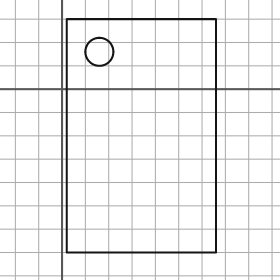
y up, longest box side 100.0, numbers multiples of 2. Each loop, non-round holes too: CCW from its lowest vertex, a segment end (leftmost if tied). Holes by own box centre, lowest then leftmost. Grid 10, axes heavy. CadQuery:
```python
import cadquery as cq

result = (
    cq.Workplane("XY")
    .moveTo(2.0, -70.0)
    .lineTo(66.0, -70.0)
    .lineTo(66.0, 30.0)
    .lineTo(2.0, 30.0)
    .close()
    .moveTo(16.0, 16.0)
    .circle(6.0)
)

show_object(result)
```